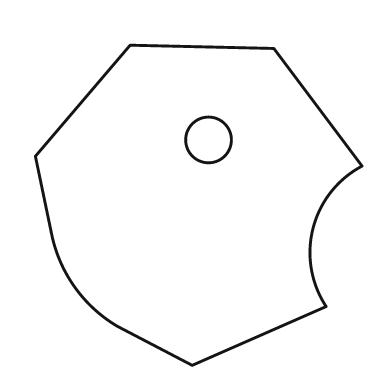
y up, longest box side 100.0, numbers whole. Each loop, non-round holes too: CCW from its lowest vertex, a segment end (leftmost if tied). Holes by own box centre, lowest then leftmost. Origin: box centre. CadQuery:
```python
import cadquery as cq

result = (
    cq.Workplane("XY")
    .moveTo(-2.0, -49.0)
    .lineTo(39.0, -31.0)
    .threePointArc((35.0, -7.0), (50.0, 12.0))
    .lineTo(23.0, 48.0)
    .lineTo(-21.0, 49.0)
    .lineTo(-50.0, 15.0)
    .lineTo(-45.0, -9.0)
    .threePointArc((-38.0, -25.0), (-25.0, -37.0))
    .close()
    .moveTo(3.0, 20.0)
    .circle(7.0)
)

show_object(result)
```